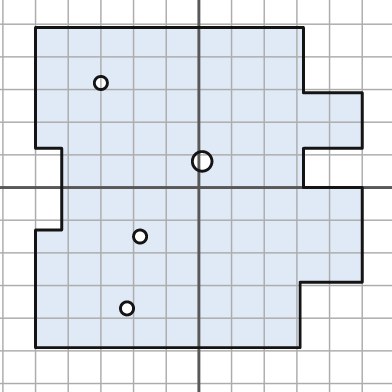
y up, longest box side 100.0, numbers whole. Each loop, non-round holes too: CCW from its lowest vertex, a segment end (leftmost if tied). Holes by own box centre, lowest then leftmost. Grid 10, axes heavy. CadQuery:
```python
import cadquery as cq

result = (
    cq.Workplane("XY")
    .moveTo(-50.0, -49.0)
    .lineTo(31.0, -49.0)
    .lineTo(31.0, -29.0)
    .lineTo(50.0, -29.0)
    .lineTo(50.0, 0.0)
    .lineTo(32.0, 0.0)
    .lineTo(32.0, 12.0)
    .lineTo(50.0, 12.0)
    .lineTo(50.0, 29.0)
    .lineTo(32.0, 29.0)
    .lineTo(32.0, 49.0)
    .lineTo(-50.0, 49.0)
    .lineTo(-50.0, 12.0)
    .lineTo(-42.0, 12.0)
    .lineTo(-42.0, -13.0)
    .lineTo(-50.0, -13.0)
    .close()
    .moveTo(-22.0, -37.0)
    .circle(2.0)
    .moveTo(-18.0, -15.0)
    .circle(2.0)
    .moveTo(1.0, 8.0)
    .circle(3.0)
    .moveTo(-30.0, 32.0)
    .circle(2.0)
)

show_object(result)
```